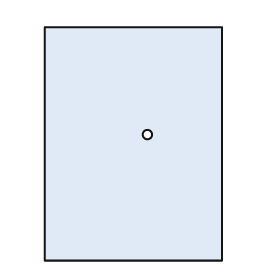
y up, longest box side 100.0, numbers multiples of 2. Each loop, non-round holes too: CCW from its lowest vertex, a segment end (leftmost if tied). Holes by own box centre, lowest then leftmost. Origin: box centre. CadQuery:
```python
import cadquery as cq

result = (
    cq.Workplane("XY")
    .moveTo(-38.0, -50.0)
    .lineTo(38.0, -50.0)
    .lineTo(38.0, 50.0)
    .lineTo(-38.0, 50.0)
    .close()
    .moveTo(6.0, 4.0)
    .circle(2.0)
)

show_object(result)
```